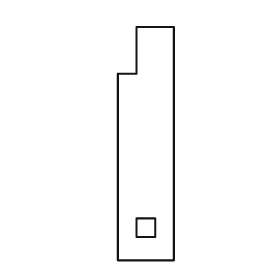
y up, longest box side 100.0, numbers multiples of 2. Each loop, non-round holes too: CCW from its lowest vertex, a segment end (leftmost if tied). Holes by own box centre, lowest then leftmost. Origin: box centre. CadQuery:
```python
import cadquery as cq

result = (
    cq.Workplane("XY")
    .moveTo(-12.0, -50.0)
    .lineTo(12.0, -50.0)
    .lineTo(12.0, 50.0)
    .lineTo(-4.0, 50.0)
    .lineTo(-4.0, 30.0)
    .lineTo(-12.0, 30.0)
    .close()
    .moveTo(-4.0, -40.0)
    .lineTo(4.0, -40.0)
    .lineTo(4.0, -32.0)
    .lineTo(-4.0, -32.0)
    .close()
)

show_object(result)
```